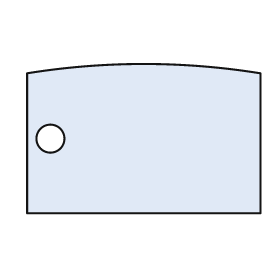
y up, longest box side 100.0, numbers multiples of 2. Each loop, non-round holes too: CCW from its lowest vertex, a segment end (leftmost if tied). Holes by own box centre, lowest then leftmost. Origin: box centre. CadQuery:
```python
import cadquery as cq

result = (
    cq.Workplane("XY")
    .moveTo(-50.0, -32.0)
    .lineTo(50.0, -32.0)
    .lineTo(50.0, 28.0)
    .threePointArc((0.0, 32.0), (-50.0, 28.0))
    .close()
    .moveTo(-40.0, 0.0)
    .circle(6.0)
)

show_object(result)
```